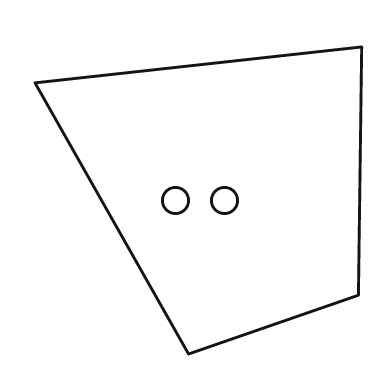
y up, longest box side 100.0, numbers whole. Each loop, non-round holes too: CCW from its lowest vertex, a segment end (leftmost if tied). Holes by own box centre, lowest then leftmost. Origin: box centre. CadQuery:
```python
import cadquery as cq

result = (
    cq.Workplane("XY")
    .moveTo(-3.0, -47.0)
    .lineTo(49.0, -29.0)
    .lineTo(50.0, 47.0)
    .lineTo(-50.0, 36.0)
    .close()
    .moveTo(-7.0, 0.0)
    .circle(4.0)
    .moveTo(8.0, 0.0)
    .circle(4.0)
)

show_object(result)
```